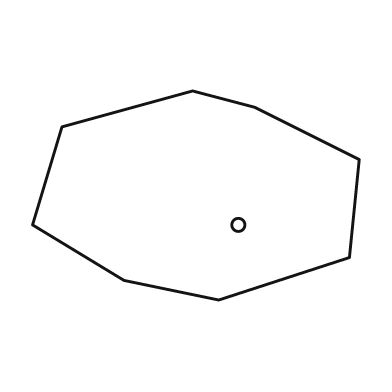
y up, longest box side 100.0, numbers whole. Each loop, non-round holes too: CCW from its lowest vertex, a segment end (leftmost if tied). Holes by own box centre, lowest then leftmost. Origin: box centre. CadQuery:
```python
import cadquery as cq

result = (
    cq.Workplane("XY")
    .moveTo(7.0, -32.0)
    .lineTo(47.0, -19.0)
    .lineTo(50.0, 11.0)
    .lineTo(18.0, 27.0)
    .lineTo(-1.0, 32.0)
    .lineTo(-41.0, 21.0)
    .lineTo(-50.0, -9.0)
    .lineTo(-22.0, -26.0)
    .close()
    .moveTo(13.0, -9.0)
    .circle(2.0)
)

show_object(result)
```